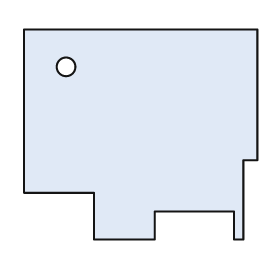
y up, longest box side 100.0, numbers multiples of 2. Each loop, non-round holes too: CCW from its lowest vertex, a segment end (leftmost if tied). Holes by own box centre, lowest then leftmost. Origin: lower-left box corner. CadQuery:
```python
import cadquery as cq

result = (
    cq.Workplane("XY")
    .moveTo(30.0, 0.0)
    .lineTo(56.0, 0.0)
    .lineTo(56.0, 12.0)
    .lineTo(90.0, 12.0)
    .lineTo(90.0, 0.0)
    .lineTo(94.0, 0.0)
    .lineTo(94.0, 34.0)
    .lineTo(100.0, 34.0)
    .lineTo(100.0, 90.0)
    .lineTo(0.0, 90.0)
    .lineTo(0.0, 20.0)
    .lineTo(30.0, 20.0)
    .close()
    .moveTo(18.0, 74.0)
    .circle(4.0)
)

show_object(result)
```